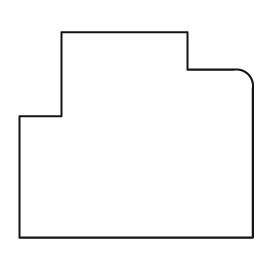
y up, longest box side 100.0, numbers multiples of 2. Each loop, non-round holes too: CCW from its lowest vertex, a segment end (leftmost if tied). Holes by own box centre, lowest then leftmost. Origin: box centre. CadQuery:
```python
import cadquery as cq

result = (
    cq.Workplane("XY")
    .moveTo(-50.0, -44.0)
    .lineTo(50.0, -44.0)
    .lineTo(50.0, 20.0)
    .threePointArc((48.0, 26.0), (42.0, 28.0))
    .lineTo(22.0, 28.0)
    .lineTo(22.0, 44.0)
    .lineTo(-32.0, 44.0)
    .lineTo(-32.0, 8.0)
    .lineTo(-50.0, 8.0)
    .close()
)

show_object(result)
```